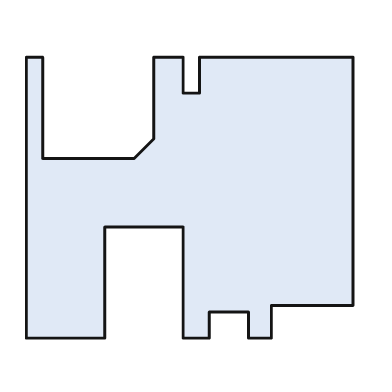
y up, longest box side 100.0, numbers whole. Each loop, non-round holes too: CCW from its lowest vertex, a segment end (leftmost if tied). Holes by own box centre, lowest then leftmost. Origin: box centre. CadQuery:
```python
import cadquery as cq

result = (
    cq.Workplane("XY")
    .moveTo(-50.0, -43.0)
    .lineTo(-26.0, -43.0)
    .lineTo(-26.0, -9.0)
    .lineTo(-2.0, -9.0)
    .lineTo(-2.0, -43.0)
    .lineTo(6.0, -43.0)
    .lineTo(6.0, -35.0)
    .lineTo(18.0, -35.0)
    .lineTo(18.0, -43.0)
    .lineTo(25.0, -43.0)
    .lineTo(25.0, -33.0)
    .lineTo(50.0, -33.0)
    .lineTo(50.0, 43.0)
    .lineTo(3.0, 43.0)
    .lineTo(3.0, 32.0)
    .lineTo(-2.0, 32.0)
    .lineTo(-2.0, 43.0)
    .lineTo(-11.0, 43.0)
    .lineTo(-11.0, 18.0)
    .lineTo(-17.0, 12.0)
    .lineTo(-45.0, 12.0)
    .lineTo(-45.0, 43.0)
    .lineTo(-50.0, 43.0)
    .close()
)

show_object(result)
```